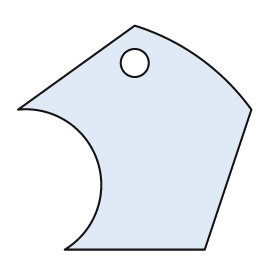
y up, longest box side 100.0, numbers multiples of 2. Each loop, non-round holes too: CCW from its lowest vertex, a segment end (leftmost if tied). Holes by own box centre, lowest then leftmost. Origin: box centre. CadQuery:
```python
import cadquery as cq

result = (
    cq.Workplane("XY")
    .moveTo(-30.0, -48.0)
    .lineTo(30.0, -48.0)
    .lineTo(50.0, 12.0)
    .threePointArc((28.0, 34.0), (0.0, 48.0))
    .lineTo(-50.0, 12.0)
    .threePointArc((-16.0, -10.0), (-30.0, -48.0))
    .close()
    .moveTo(0.0, 32.0)
    .circle(6.0)
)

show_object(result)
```